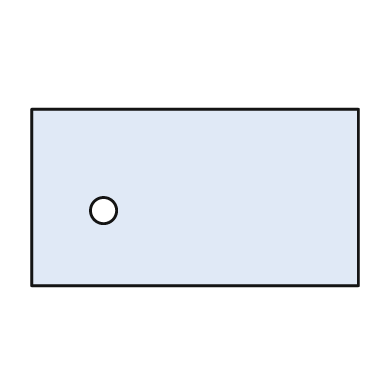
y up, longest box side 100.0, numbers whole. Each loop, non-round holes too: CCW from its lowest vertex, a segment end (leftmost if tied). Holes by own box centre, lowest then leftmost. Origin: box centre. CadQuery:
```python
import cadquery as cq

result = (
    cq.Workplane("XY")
    .moveTo(-50.0, -27.0)
    .lineTo(50.0, -27.0)
    .lineTo(50.0, 27.0)
    .lineTo(-50.0, 27.0)
    .close()
    .moveTo(-28.0, -4.0)
    .circle(4.0)
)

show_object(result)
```